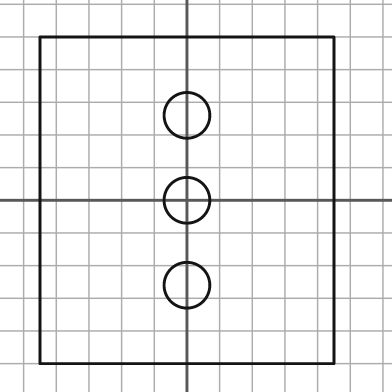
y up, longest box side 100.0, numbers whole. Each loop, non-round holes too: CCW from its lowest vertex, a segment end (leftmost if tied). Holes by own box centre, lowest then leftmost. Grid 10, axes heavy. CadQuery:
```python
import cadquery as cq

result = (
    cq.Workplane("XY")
    .moveTo(-45.0, -50.0)
    .lineTo(45.0, -50.0)
    .lineTo(45.0, 50.0)
    .lineTo(-45.0, 50.0)
    .close()
    .moveTo(0.0, -26.0)
    .circle(7.0)
    .moveTo(0.0, 0.0)
    .circle(7.0)
    .moveTo(0.0, 26.0)
    .circle(7.0)
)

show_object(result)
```